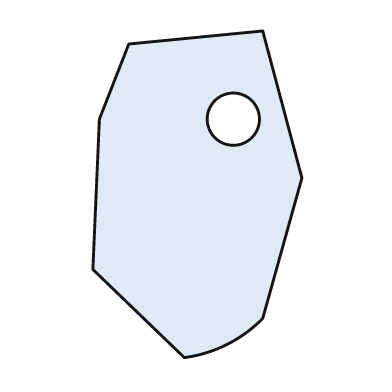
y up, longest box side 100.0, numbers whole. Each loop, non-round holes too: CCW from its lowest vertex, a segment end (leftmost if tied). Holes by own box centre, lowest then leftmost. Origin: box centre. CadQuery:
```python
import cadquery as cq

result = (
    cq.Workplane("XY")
    .moveTo(-4.0, -50.0)
    .threePointArc((9.0, -46.0), (20.0, -38.0))
    .lineTo(32.0, 5.0)
    .lineTo(20.0, 50.0)
    .lineTo(-21.0, 46.0)
    .lineTo(-30.0, 23.0)
    .lineTo(-32.0, -23.0)
    .close()
    .moveTo(11.0, 23.0)
    .circle(8.0)
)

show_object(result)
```